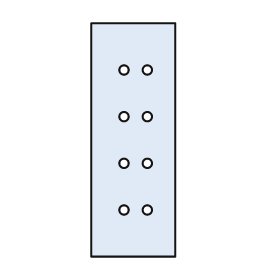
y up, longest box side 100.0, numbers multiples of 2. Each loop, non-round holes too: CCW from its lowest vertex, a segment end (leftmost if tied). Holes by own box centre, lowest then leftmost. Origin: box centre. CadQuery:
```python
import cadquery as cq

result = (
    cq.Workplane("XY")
    .moveTo(-18.0, -50.0)
    .lineTo(18.0, -50.0)
    .lineTo(18.0, 50.0)
    .lineTo(-18.0, 50.0)
    .close()
    .moveTo(-4.0, -30.0)
    .circle(2.0)
    .moveTo(6.0, -30.0)
    .circle(2.0)
    .moveTo(-4.0, -10.0)
    .circle(2.0)
    .moveTo(6.0, -10.0)
    .circle(2.0)
    .moveTo(-4.0, 10.0)
    .circle(2.0)
    .moveTo(6.0, 10.0)
    .circle(2.0)
    .moveTo(-4.0, 30.0)
    .circle(2.0)
    .moveTo(6.0, 30.0)
    .circle(2.0)
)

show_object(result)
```